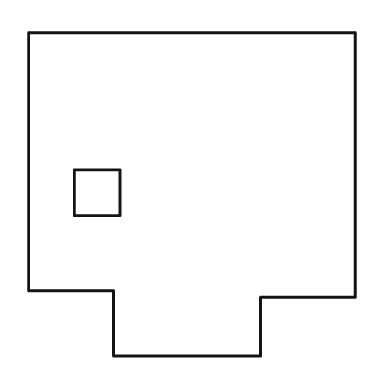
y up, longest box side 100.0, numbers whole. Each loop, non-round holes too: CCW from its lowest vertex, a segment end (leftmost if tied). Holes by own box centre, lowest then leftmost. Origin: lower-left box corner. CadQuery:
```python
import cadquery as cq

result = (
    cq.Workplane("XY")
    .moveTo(26.0, 0.0)
    .lineTo(71.0, 0.0)
    .lineTo(71.0, 18.0)
    .lineTo(100.0, 18.0)
    .lineTo(100.0, 99.0)
    .lineTo(0.0, 99.0)
    .lineTo(0.0, 20.0)
    .lineTo(26.0, 20.0)
    .close()
    .moveTo(14.0, 43.0)
    .lineTo(28.0, 43.0)
    .lineTo(28.0, 57.0)
    .lineTo(14.0, 57.0)
    .close()
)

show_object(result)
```